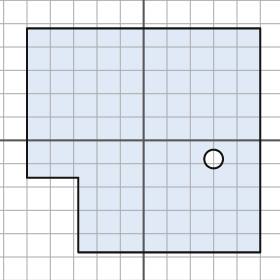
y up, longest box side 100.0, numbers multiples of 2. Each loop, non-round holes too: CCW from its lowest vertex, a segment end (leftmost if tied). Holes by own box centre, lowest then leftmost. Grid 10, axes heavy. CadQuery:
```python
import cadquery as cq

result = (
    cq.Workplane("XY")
    .moveTo(-28.0, -48.0)
    .lineTo(50.0, -48.0)
    .lineTo(50.0, 48.0)
    .lineTo(-50.0, 48.0)
    .lineTo(-50.0, -16.0)
    .lineTo(-28.0, -16.0)
    .close()
    .moveTo(30.0, -8.0)
    .circle(4.0)
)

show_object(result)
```